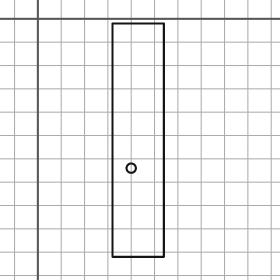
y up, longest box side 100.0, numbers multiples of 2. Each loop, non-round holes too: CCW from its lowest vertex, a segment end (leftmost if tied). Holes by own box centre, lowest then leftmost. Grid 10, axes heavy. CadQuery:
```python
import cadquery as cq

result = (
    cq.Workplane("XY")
    .moveTo(32.0, -102.0)
    .lineTo(54.0, -102.0)
    .lineTo(54.0, -2.0)
    .lineTo(32.0, -2.0)
    .close()
    .moveTo(40.0, -64.0)
    .circle(2.0)
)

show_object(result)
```